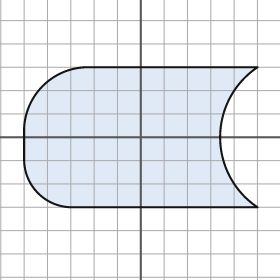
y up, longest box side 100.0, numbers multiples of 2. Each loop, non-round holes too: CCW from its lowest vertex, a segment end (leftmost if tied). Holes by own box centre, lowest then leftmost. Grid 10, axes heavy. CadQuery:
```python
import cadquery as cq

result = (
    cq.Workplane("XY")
    .moveTo(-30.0, -30.0)
    .lineTo(50.0, -30.0)
    .threePointArc((34.0, 0.0), (50.0, 30.0))
    .lineTo(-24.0, 30.0)
    .threePointArc((-42.0, 22.0), (-50.0, 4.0))
    .lineTo(-50.0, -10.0)
    .threePointArc((-44.0, -24.0), (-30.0, -30.0))
    .close()
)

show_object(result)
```